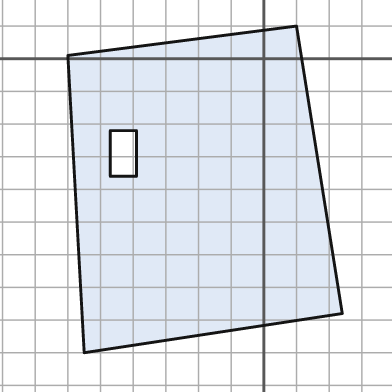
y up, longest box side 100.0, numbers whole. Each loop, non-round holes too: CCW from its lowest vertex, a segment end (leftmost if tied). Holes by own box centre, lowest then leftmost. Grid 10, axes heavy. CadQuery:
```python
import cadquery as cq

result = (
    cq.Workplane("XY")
    .moveTo(-55.0, -90.0)
    .lineTo(24.0, -78.0)
    .lineTo(10.0, 10.0)
    .lineTo(-60.0, 1.0)
    .close()
    .moveTo(-47.0, -36.0)
    .lineTo(-39.0, -36.0)
    .lineTo(-39.0, -22.0)
    .lineTo(-47.0, -22.0)
    .close()
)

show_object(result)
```